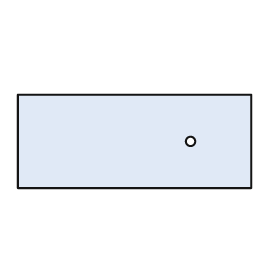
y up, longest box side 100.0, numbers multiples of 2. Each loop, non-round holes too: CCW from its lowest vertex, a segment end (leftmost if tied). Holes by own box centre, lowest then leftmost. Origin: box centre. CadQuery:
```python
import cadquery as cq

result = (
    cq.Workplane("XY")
    .moveTo(-50.0, -20.0)
    .lineTo(50.0, -20.0)
    .lineTo(50.0, 20.0)
    .lineTo(-50.0, 20.0)
    .close()
    .moveTo(24.0, 0.0)
    .circle(2.0)
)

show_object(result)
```